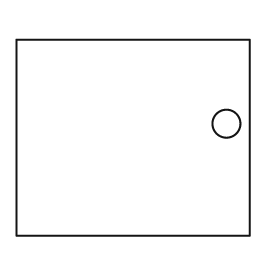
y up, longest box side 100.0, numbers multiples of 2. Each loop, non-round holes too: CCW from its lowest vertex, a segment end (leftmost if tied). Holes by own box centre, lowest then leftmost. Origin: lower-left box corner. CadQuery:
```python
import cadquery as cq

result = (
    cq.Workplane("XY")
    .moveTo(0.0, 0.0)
    .lineTo(100.0, 0.0)
    .lineTo(100.0, 84.0)
    .lineTo(0.0, 84.0)
    .close()
    .moveTo(90.0, 48.0)
    .circle(6.0)
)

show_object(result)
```